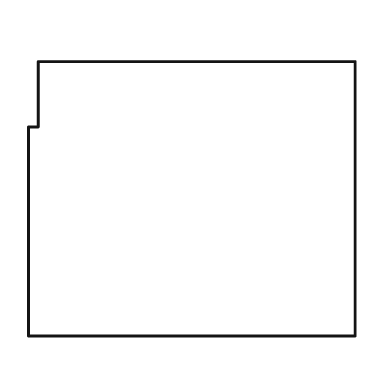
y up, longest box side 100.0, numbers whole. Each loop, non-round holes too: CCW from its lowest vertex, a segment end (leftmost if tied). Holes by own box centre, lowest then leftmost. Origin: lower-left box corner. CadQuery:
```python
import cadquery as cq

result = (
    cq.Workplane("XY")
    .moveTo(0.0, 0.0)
    .lineTo(100.0, 0.0)
    .lineTo(100.0, 84.0)
    .lineTo(3.0, 84.0)
    .lineTo(3.0, 64.0)
    .lineTo(0.0, 64.0)
    .close()
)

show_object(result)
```